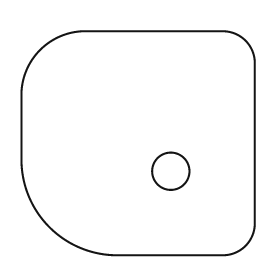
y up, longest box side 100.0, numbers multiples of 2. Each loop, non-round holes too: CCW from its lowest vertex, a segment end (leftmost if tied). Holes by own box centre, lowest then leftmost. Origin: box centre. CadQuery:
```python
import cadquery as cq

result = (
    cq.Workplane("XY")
    .moveTo(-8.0, -48.0)
    .lineTo(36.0, -48.0)
    .threePointArc((46.0, -44.0), (50.0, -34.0))
    .lineTo(50.0, 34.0)
    .threePointArc((46.0, 44.0), (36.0, 48.0))
    .lineTo(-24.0, 48.0)
    .threePointArc((-42.0, 40.0), (-50.0, 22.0))
    .lineTo(-50.0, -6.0)
    .threePointArc((-38.0, -36.0), (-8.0, -48.0))
    .close()
    .moveTo(14.0, -12.0)
    .circle(8.0)
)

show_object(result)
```